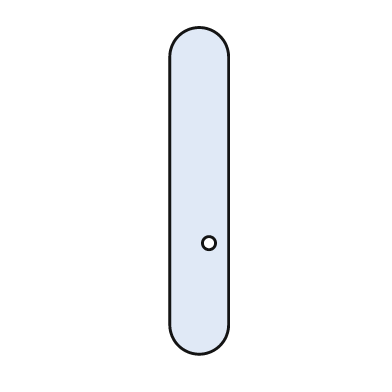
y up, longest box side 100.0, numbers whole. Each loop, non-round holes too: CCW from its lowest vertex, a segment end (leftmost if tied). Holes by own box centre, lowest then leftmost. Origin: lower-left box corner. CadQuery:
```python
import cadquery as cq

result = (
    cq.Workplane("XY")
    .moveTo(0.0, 9.0)
    .threePointArc((9.0, 0.0), (18.0, 9.0))
    .lineTo(18.0, 91.0)
    .threePointArc((9.0, 100.0), (0.0, 91.0))
    .close()
    .moveTo(12.0, 34.0)
    .circle(2.0)
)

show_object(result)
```